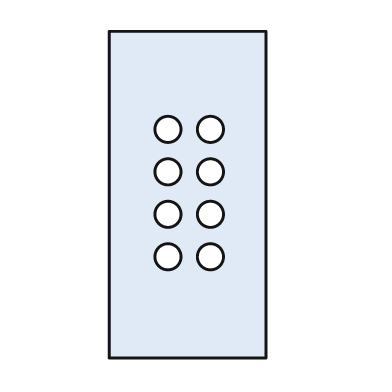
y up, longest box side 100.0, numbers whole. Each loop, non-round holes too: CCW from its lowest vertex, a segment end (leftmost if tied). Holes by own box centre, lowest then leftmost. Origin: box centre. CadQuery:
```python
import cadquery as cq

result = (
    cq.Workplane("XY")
    .moveTo(-24.0, -50.0)
    .lineTo(24.0, -50.0)
    .lineTo(24.0, 50.0)
    .lineTo(-24.0, 50.0)
    .close()
    .moveTo(-6.0, -19.0)
    .circle(4.0)
    .moveTo(7.0, -19.0)
    .circle(4.0)
    .moveTo(-6.0, -6.0)
    .circle(4.0)
    .moveTo(7.0, -6.0)
    .circle(4.0)
    .moveTo(-6.0, 7.0)
    .circle(4.0)
    .moveTo(7.0, 7.0)
    .circle(4.0)
    .moveTo(-6.0, 20.0)
    .circle(4.0)
    .moveTo(7.0, 20.0)
    .circle(4.0)
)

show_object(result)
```